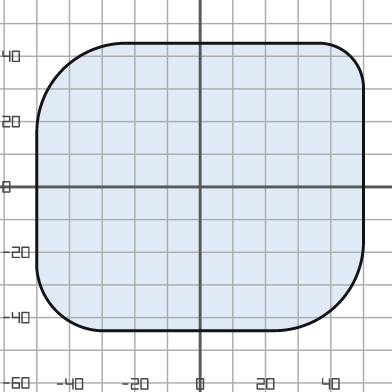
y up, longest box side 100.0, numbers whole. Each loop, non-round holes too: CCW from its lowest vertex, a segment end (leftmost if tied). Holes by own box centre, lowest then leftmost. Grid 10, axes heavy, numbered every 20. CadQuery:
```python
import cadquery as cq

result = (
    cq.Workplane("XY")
    .moveTo(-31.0, -44.0)
    .lineTo(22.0, -44.0)
    .threePointArc((42.0, -36.0), (50.0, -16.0))
    .lineTo(50.0, 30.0)
    .threePointArc((46.0, 40.0), (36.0, 44.0))
    .lineTo(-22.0, 44.0)
    .threePointArc((-42.0, 36.0), (-50.0, 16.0))
    .lineTo(-50.0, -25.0)
    .threePointArc((-44.0, -38.0), (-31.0, -44.0))
    .close()
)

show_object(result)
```